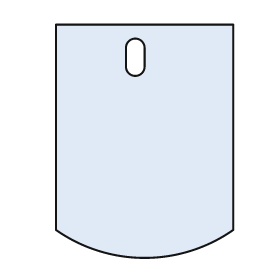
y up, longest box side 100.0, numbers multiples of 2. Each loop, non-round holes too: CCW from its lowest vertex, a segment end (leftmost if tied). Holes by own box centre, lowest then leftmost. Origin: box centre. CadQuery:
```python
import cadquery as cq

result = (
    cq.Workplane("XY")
    .moveTo(-38.0, -38.0)
    .threePointArc((0.0, -50.0), (38.0, -38.0))
    .lineTo(38.0, 50.0)
    .lineTo(-38.0, 50.0)
    .close()
    .moveTo(-8.0, 32.0)
    .threePointArc((-4.0, 28.0), (0.0, 32.0))
    .lineTo(0.0, 40.0)
    .threePointArc((-4.0, 44.0), (-8.0, 40.0))
    .close()
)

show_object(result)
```